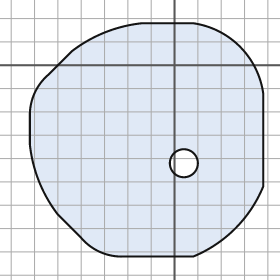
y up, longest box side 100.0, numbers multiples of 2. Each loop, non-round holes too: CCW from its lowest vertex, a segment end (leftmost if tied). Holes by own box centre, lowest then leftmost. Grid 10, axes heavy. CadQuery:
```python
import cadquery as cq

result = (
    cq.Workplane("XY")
    .moveTo(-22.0, -82.0)
    .lineTo(8.0, -82.0)
    .threePointArc((26.0, -70.0), (38.0, -52.0))
    .lineTo(38.0, -12.0)
    .threePointArc((28.0, 8.0), (8.0, 18.0))
    .lineTo(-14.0, 18.0)
    .threePointArc((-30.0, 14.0), (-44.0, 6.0))
    .lineTo(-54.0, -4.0)
    .threePointArc((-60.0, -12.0), (-62.0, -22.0))
    .lineTo(-62.0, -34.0)
    .threePointArc((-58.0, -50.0), (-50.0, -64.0))
    .lineTo(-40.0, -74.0)
    .threePointArc((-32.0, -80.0), (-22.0, -82.0))
    .close()
    .moveTo(4.0, -42.0)
    .circle(6.0)
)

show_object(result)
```